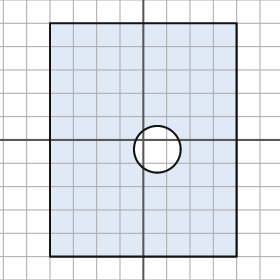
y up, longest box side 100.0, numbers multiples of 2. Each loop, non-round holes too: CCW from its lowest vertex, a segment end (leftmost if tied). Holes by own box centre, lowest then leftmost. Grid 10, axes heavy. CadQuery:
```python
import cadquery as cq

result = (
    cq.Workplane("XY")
    .moveTo(-40.0, -50.0)
    .lineTo(40.0, -50.0)
    .lineTo(40.0, 50.0)
    .lineTo(-40.0, 50.0)
    .close()
    .moveTo(6.0, -4.0)
    .circle(10.0)
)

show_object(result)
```